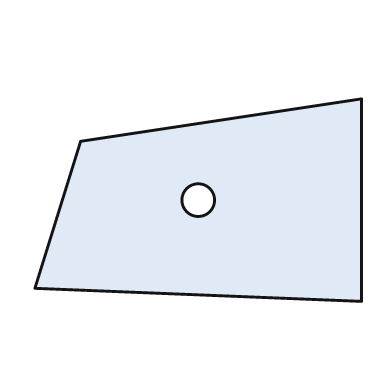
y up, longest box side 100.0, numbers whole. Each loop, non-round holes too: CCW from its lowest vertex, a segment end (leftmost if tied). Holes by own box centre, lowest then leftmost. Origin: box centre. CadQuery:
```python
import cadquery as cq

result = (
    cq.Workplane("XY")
    .moveTo(50.0, -31.0)
    .lineTo(50.0, 31.0)
    .lineTo(-36.0, 18.0)
    .lineTo(-50.0, -27.0)
    .close()
    .moveTo(0.0, 0.0)
    .circle(5.0)
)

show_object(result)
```